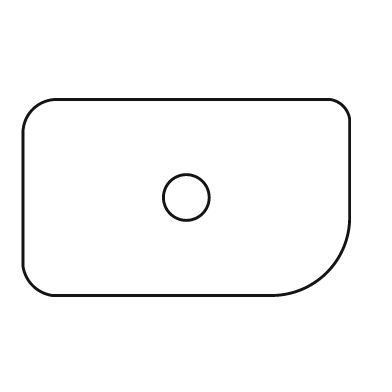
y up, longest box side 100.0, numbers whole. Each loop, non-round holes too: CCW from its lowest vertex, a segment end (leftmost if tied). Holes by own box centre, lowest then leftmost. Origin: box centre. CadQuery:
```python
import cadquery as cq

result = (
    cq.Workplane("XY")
    .moveTo(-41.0, -30.0)
    .lineTo(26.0, -30.0)
    .threePointArc((43.0, -23.0), (50.0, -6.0))
    .lineTo(50.0, 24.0)
    .threePointArc((48.0, 28.0), (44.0, 30.0))
    .lineTo(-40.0, 30.0)
    .threePointArc((-47.0, 27.0), (-50.0, 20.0))
    .lineTo(-50.0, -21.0)
    .threePointArc((-47.0, -27.0), (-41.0, -30.0))
    .close()
    .moveTo(0.0, 0.0)
    .circle(7.0)
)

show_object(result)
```